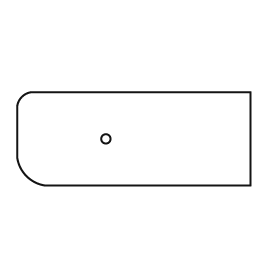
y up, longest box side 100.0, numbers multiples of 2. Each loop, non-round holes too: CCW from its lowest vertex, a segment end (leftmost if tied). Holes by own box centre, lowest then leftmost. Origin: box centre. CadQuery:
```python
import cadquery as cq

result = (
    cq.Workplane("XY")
    .moveTo(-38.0, -20.0)
    .lineTo(50.0, -20.0)
    .lineTo(50.0, 20.0)
    .lineTo(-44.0, 20.0)
    .threePointArc((-48.0, 18.0), (-50.0, 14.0))
    .lineTo(-50.0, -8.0)
    .threePointArc((-46.0, -16.0), (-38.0, -20.0))
    .close()
    .moveTo(-12.0, 0.0)
    .circle(2.0)
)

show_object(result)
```